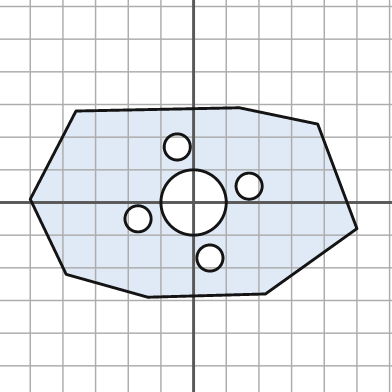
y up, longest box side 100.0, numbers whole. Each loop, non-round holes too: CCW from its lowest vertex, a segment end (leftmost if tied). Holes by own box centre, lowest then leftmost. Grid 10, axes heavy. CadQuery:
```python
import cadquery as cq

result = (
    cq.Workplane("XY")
    .moveTo(-14.0, -29.0)
    .lineTo(22.0, -28.0)
    .lineTo(50.0, -8.0)
    .lineTo(38.0, 24.0)
    .lineTo(14.0, 29.0)
    .lineTo(-36.0, 28.0)
    .lineTo(-50.0, 1.0)
    .lineTo(-39.0, -22.0)
    .close()
    .moveTo(5.0, -17.0)
    .circle(4.0)
    .moveTo(-17.0, -5.0)
    .circle(4.0)
    .moveTo(0.0, 0.0)
    .circle(10.0)
    .moveTo(17.0, 5.0)
    .circle(4.0)
    .moveTo(-5.0, 17.0)
    .circle(4.0)
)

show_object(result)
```